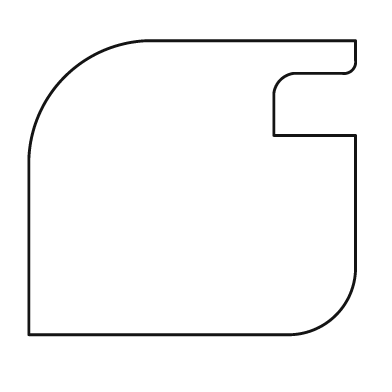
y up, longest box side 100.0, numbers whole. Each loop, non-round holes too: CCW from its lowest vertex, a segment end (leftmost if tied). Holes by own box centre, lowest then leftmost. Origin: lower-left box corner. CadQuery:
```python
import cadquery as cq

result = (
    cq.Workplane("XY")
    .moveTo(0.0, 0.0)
    .lineTo(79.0, 0.0)
    .threePointArc((94.0, 6.0), (100.0, 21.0))
    .lineTo(100.0, 61.0)
    .lineTo(75.0, 61.0)
    .lineTo(75.0, 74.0)
    .threePointArc((77.0, 78.0), (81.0, 80.0))
    .lineTo(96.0, 80.0)
    .threePointArc((99.0, 81.0), (100.0, 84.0))
    .lineTo(100.0, 90.0)
    .lineTo(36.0, 90.0)
    .threePointArc((11.0, 79.0), (0.0, 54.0))
    .close()
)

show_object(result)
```